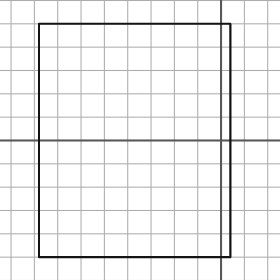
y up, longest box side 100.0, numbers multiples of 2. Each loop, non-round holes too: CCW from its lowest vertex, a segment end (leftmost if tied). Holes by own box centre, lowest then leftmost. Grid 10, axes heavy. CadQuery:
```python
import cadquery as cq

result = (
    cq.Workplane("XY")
    .moveTo(-78.0, -50.0)
    .lineTo(4.0, -50.0)
    .lineTo(4.0, 50.0)
    .lineTo(-78.0, 50.0)
    .close()
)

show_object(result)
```